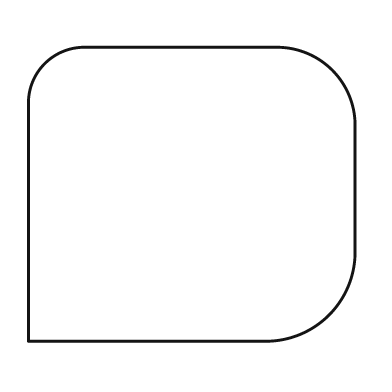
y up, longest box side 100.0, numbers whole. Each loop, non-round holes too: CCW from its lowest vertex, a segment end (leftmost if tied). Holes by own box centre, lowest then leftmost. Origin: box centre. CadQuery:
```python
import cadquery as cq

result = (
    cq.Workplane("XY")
    .moveTo(-50.0, -45.0)
    .lineTo(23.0, -45.0)
    .threePointArc((42.0, -37.0), (50.0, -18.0))
    .lineTo(50.0, 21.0)
    .threePointArc((43.0, 38.0), (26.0, 45.0))
    .lineTo(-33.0, 45.0)
    .threePointArc((-45.0, 40.0), (-50.0, 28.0))
    .close()
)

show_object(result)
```